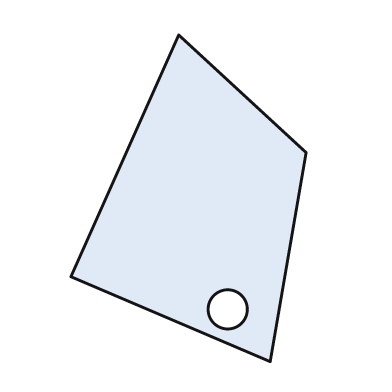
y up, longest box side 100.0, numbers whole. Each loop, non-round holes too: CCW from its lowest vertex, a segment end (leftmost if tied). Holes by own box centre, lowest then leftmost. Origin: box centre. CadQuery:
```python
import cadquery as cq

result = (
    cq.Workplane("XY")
    .moveTo(25.0, -50.0)
    .lineTo(36.0, 14.0)
    .lineTo(-3.0, 50.0)
    .lineTo(-36.0, -24.0)
    .close()
    .moveTo(12.0, -34.0)
    .circle(6.0)
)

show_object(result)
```